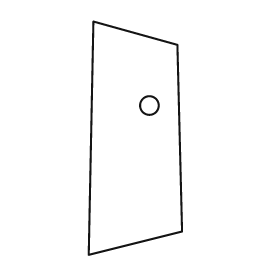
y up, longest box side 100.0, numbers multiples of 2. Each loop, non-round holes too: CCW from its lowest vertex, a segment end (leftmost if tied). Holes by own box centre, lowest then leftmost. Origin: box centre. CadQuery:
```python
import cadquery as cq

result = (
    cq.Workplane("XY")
    .moveTo(-20.0, -50.0)
    .lineTo(20.0, -40.0)
    .lineTo(18.0, 40.0)
    .lineTo(-18.0, 50.0)
    .close()
    .moveTo(6.0, 14.0)
    .circle(4.0)
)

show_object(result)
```